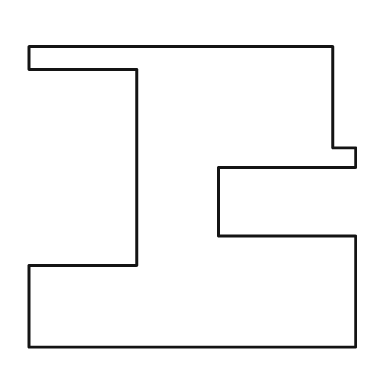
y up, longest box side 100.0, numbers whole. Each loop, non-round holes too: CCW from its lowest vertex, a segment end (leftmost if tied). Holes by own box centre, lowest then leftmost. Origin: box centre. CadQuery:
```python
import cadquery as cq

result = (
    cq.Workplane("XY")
    .moveTo(-50.0, -46.0)
    .lineTo(50.0, -46.0)
    .lineTo(50.0, -12.0)
    .lineTo(8.0, -12.0)
    .lineTo(8.0, 9.0)
    .lineTo(50.0, 9.0)
    .lineTo(50.0, 15.0)
    .lineTo(43.0, 15.0)
    .lineTo(43.0, 46.0)
    .lineTo(-50.0, 46.0)
    .lineTo(-50.0, 39.0)
    .lineTo(-17.0, 39.0)
    .lineTo(-17.0, -21.0)
    .lineTo(-50.0, -21.0)
    .close()
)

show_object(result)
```